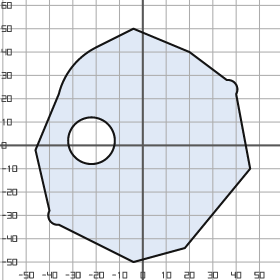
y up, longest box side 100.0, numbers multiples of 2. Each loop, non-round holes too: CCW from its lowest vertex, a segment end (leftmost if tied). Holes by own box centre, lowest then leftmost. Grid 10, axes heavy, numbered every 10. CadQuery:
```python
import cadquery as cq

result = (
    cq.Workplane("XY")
    .moveTo(-4.0, -50.0)
    .lineTo(18.0, -44.0)
    .lineTo(46.0, -10.0)
    .lineTo(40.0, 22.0)
    .threePointArc((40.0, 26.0), (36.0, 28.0))
    .lineTo(20.0, 40.0)
    .lineTo(-4.0, 50.0)
    .lineTo(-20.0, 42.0)
    .threePointArc((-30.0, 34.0), (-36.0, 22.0))
    .lineTo(-46.0, -2.0)
    .lineTo(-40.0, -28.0)
    .threePointArc((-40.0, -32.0), (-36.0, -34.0))
    .close()
    .moveTo(-22.0, 2.0)
    .circle(10.0)
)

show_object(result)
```